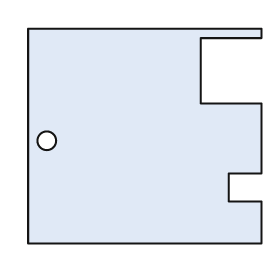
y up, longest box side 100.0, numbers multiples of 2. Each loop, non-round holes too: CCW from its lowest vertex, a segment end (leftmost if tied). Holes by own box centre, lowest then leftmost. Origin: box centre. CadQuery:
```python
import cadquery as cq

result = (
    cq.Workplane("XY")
    .moveTo(-50.0, -46.0)
    .lineTo(50.0, -46.0)
    .lineTo(50.0, -28.0)
    .lineTo(36.0, -28.0)
    .lineTo(36.0, -16.0)
    .lineTo(50.0, -16.0)
    .lineTo(50.0, 14.0)
    .lineTo(24.0, 14.0)
    .lineTo(24.0, 42.0)
    .lineTo(50.0, 42.0)
    .lineTo(50.0, 46.0)
    .lineTo(-50.0, 46.0)
    .close()
    .moveTo(-42.0, -2.0)
    .circle(4.0)
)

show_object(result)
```